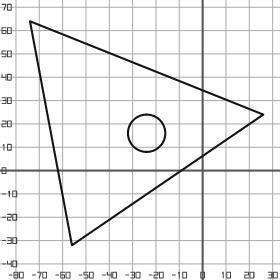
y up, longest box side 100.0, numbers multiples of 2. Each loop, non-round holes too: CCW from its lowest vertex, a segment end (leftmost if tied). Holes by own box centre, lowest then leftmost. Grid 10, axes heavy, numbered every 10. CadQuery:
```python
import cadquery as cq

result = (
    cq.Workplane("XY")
    .moveTo(-56.0, -32.0)
    .lineTo(26.0, 24.0)
    .lineTo(-74.0, 64.0)
    .close()
    .moveTo(-24.0, 16.0)
    .circle(8.0)
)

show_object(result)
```